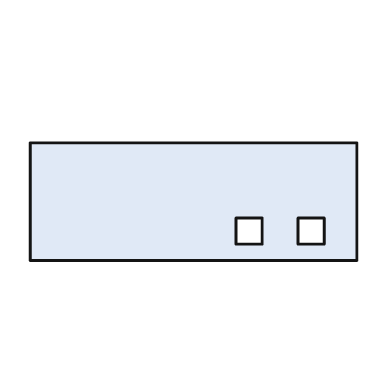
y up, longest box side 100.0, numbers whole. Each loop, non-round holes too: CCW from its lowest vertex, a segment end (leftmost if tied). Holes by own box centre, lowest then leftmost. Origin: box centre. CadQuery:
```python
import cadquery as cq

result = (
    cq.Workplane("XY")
    .moveTo(-50.0, -18.0)
    .lineTo(50.0, -18.0)
    .lineTo(50.0, 18.0)
    .lineTo(-50.0, 18.0)
    .close()
    .moveTo(13.0, -13.0)
    .lineTo(21.0, -13.0)
    .lineTo(21.0, -5.0)
    .lineTo(13.0, -5.0)
    .close()
    .moveTo(32.0, -13.0)
    .lineTo(40.0, -13.0)
    .lineTo(40.0, -5.0)
    .lineTo(32.0, -5.0)
    .close()
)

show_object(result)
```